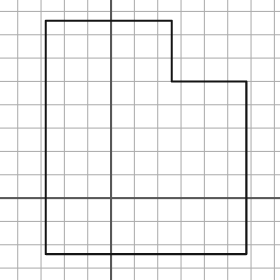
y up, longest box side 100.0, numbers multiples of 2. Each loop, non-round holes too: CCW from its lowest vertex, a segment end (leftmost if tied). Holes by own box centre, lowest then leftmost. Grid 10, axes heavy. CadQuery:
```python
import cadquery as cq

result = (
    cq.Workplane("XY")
    .moveTo(-28.0, -24.0)
    .lineTo(58.0, -24.0)
    .lineTo(58.0, 50.0)
    .lineTo(26.0, 50.0)
    .lineTo(26.0, 76.0)
    .lineTo(-28.0, 76.0)
    .close()
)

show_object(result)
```